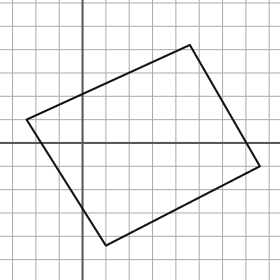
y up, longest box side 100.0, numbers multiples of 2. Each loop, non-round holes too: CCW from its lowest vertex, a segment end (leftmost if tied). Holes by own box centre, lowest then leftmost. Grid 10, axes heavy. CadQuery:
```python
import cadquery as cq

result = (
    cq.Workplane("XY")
    .moveTo(10.0, -44.0)
    .lineTo(76.0, -10.0)
    .lineTo(46.0, 42.0)
    .lineTo(-24.0, 10.0)
    .close()
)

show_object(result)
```